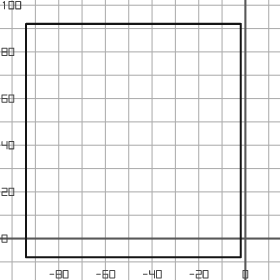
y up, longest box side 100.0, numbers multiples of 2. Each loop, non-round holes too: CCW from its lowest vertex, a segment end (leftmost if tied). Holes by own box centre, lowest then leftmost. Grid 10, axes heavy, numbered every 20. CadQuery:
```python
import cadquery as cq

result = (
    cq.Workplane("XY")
    .moveTo(-94.0, -8.0)
    .lineTo(-2.0, -8.0)
    .lineTo(-2.0, 92.0)
    .lineTo(-94.0, 92.0)
    .close()
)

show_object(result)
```